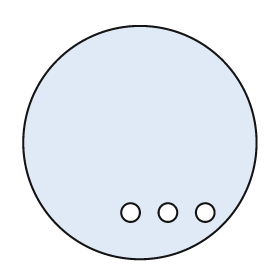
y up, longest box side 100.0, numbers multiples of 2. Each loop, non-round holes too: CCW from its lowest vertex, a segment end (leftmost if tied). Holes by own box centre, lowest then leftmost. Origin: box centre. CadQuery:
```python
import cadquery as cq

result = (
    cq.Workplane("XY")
    .moveTo(0.0, 0.0)
    .circle(50.0)
    .moveTo(-4.0, -30.0)
    .circle(4.0)
    .moveTo(12.0, -30.0)
    .circle(4.0)
    .moveTo(28.0, -30.0)
    .circle(4.0)
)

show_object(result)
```